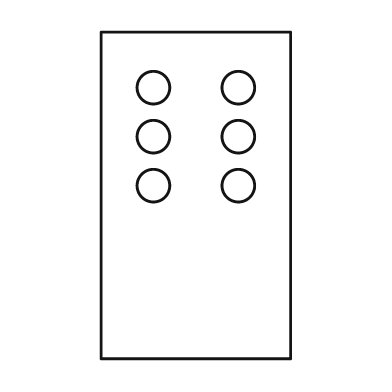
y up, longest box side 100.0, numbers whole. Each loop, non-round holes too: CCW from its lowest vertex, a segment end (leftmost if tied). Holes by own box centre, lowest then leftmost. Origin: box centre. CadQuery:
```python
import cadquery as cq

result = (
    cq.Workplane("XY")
    .moveTo(-29.0, -50.0)
    .lineTo(29.0, -50.0)
    .lineTo(29.0, 50.0)
    .lineTo(-29.0, 50.0)
    .close()
    .moveTo(-13.0, 3.0)
    .circle(5.0)
    .moveTo(13.0, 3.0)
    .circle(5.0)
    .moveTo(-13.0, 18.0)
    .circle(5.0)
    .moveTo(13.0, 18.0)
    .circle(5.0)
    .moveTo(-13.0, 33.0)
    .circle(5.0)
    .moveTo(13.0, 33.0)
    .circle(5.0)
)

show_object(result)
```